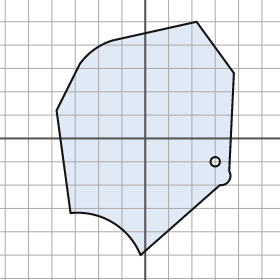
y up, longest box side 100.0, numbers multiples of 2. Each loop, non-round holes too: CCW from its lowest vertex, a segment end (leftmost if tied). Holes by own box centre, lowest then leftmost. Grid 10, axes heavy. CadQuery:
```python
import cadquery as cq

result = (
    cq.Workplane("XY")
    .moveTo(-2.0, -50.0)
    .lineTo(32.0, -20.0)
    .threePointArc((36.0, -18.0), (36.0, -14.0))
    .lineTo(38.0, 28.0)
    .lineTo(22.0, 50.0)
    .lineTo(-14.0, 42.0)
    .threePointArc((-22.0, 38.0), (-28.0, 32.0))
    .lineTo(-38.0, 12.0)
    .lineTo(-32.0, -32.0)
    .threePointArc((-14.0, -36.0), (-2.0, -50.0))
    .close()
    .moveTo(30.0, -10.0)
    .circle(2.0)
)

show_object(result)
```